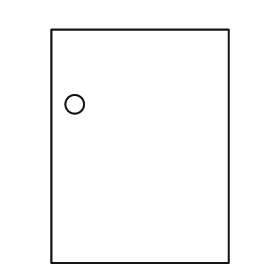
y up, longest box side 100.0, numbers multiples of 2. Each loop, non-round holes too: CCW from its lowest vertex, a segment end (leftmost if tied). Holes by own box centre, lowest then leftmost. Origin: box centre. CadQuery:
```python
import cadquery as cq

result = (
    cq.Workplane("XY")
    .moveTo(-38.0, -50.0)
    .lineTo(38.0, -50.0)
    .lineTo(38.0, 50.0)
    .lineTo(-38.0, 50.0)
    .close()
    .moveTo(-28.0, 18.0)
    .circle(4.0)
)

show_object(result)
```